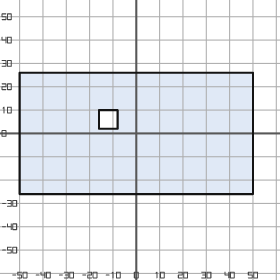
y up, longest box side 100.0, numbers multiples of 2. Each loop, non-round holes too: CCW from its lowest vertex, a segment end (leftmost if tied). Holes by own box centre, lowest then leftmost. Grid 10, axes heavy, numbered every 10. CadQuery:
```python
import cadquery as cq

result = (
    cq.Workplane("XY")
    .moveTo(-50.0, -26.0)
    .lineTo(50.0, -26.0)
    .lineTo(50.0, 26.0)
    .lineTo(-50.0, 26.0)
    .close()
    .moveTo(-16.0, 2.0)
    .lineTo(-8.0, 2.0)
    .lineTo(-8.0, 10.0)
    .lineTo(-16.0, 10.0)
    .close()
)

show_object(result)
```